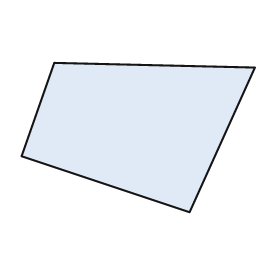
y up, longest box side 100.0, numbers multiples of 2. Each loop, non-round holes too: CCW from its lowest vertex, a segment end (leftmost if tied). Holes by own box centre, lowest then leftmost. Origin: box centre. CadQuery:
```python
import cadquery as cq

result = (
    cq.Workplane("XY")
    .moveTo(22.0, -32.0)
    .lineTo(50.0, 30.0)
    .lineTo(-36.0, 32.0)
    .lineTo(-50.0, -8.0)
    .close()
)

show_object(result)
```